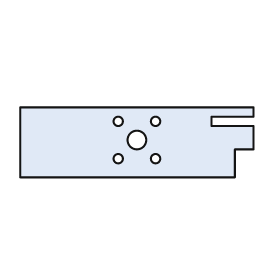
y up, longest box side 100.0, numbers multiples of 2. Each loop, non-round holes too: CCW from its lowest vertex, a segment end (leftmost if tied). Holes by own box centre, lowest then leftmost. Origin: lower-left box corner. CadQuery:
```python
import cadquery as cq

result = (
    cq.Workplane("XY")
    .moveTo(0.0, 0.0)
    .lineTo(92.0, 0.0)
    .lineTo(92.0, 12.0)
    .lineTo(100.0, 12.0)
    .lineTo(100.0, 22.0)
    .lineTo(82.0, 22.0)
    .lineTo(82.0, 26.0)
    .lineTo(100.0, 26.0)
    .lineTo(100.0, 30.0)
    .lineTo(0.0, 30.0)
    .close()
    .moveTo(42.0, 8.0)
    .circle(2.0)
    .moveTo(58.0, 8.0)
    .circle(2.0)
    .moveTo(50.0, 16.0)
    .circle(4.0)
    .moveTo(42.0, 24.0)
    .circle(2.0)
    .moveTo(58.0, 24.0)
    .circle(2.0)
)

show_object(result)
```